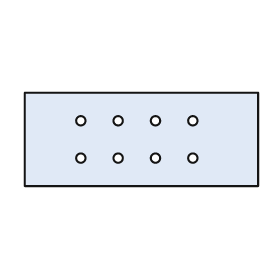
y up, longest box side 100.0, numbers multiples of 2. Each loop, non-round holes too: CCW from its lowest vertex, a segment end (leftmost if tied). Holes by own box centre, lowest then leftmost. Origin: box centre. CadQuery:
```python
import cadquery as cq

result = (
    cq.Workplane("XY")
    .moveTo(-50.0, -20.0)
    .lineTo(50.0, -20.0)
    .lineTo(50.0, 20.0)
    .lineTo(-50.0, 20.0)
    .close()
    .moveTo(-26.0, -8.0)
    .circle(2.0)
    .moveTo(-10.0, -8.0)
    .circle(2.0)
    .moveTo(6.0, -8.0)
    .circle(2.0)
    .moveTo(22.0, -8.0)
    .circle(2.0)
    .moveTo(-26.0, 8.0)
    .circle(2.0)
    .moveTo(-10.0, 8.0)
    .circle(2.0)
    .moveTo(6.0, 8.0)
    .circle(2.0)
    .moveTo(22.0, 8.0)
    .circle(2.0)
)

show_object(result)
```